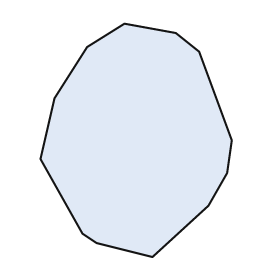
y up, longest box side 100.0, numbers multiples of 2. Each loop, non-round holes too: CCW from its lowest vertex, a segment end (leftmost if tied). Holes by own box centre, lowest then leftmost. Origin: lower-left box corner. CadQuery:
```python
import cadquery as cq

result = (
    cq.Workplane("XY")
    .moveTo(48.0, 0.0)
    .lineTo(72.0, 22.0)
    .lineTo(80.0, 36.0)
    .lineTo(82.0, 50.0)
    .lineTo(68.0, 88.0)
    .lineTo(58.0, 96.0)
    .lineTo(36.0, 100.0)
    .lineTo(20.0, 90.0)
    .lineTo(6.0, 68.0)
    .lineTo(0.0, 42.0)
    .lineTo(18.0, 10.0)
    .lineTo(24.0, 6.0)
    .close()
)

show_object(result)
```